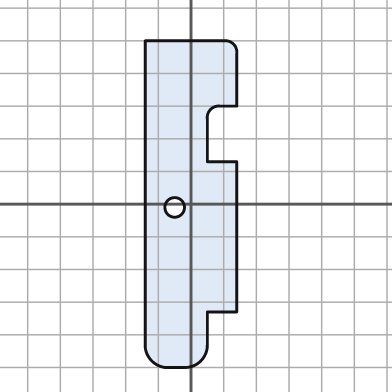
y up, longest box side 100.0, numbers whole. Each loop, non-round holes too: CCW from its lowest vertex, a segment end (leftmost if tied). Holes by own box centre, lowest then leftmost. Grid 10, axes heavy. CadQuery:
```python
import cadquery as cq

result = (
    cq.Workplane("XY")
    .moveTo(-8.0, -50.0)
    .lineTo(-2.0, -50.0)
    .threePointArc((3.0, -48.0), (5.0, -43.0))
    .lineTo(5.0, -33.0)
    .lineTo(14.0, -33.0)
    .lineTo(14.0, 13.0)
    .lineTo(5.0, 13.0)
    .lineTo(5.0, 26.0)
    .threePointArc((6.0, 29.0), (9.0, 30.0))
    .lineTo(14.0, 30.0)
    .lineTo(14.0, 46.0)
    .threePointArc((13.0, 49.0), (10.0, 50.0))
    .lineTo(-14.0, 50.0)
    .lineTo(-14.0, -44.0)
    .threePointArc((-12.0, -48.0), (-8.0, -50.0))
    .close()
    .moveTo(-5.0, -1.0)
    .circle(3.0)
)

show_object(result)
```